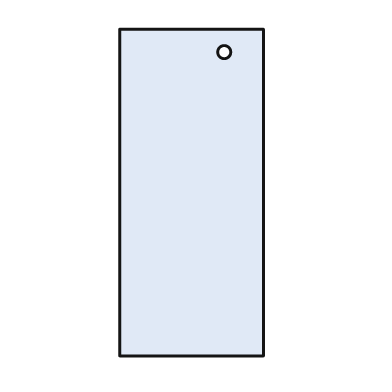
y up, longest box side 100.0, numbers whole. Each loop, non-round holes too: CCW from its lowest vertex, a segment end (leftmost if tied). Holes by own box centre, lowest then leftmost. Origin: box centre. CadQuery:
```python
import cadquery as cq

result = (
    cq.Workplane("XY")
    .moveTo(-22.0, -50.0)
    .lineTo(22.0, -50.0)
    .lineTo(22.0, 50.0)
    .lineTo(-22.0, 50.0)
    .close()
    .moveTo(10.0, 43.0)
    .circle(2.0)
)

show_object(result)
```